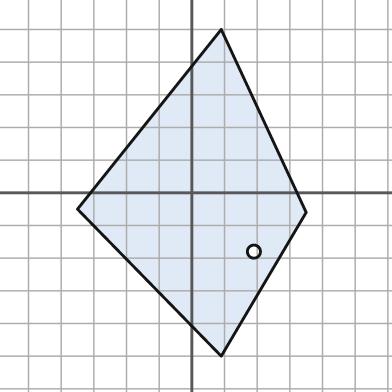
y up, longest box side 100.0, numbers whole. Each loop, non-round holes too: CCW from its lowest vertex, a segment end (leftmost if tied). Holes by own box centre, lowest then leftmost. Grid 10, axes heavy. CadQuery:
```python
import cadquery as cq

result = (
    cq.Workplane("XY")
    .moveTo(9.0, -50.0)
    .lineTo(35.0, -6.0)
    .lineTo(9.0, 50.0)
    .lineTo(-35.0, -5.0)
    .close()
    .moveTo(19.0, -18.0)
    .circle(2.0)
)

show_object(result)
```